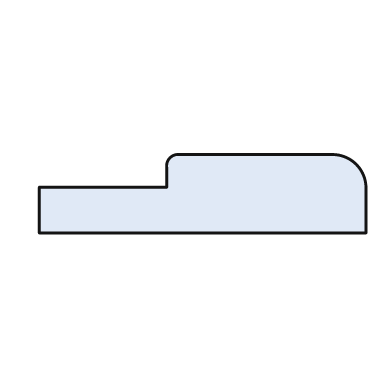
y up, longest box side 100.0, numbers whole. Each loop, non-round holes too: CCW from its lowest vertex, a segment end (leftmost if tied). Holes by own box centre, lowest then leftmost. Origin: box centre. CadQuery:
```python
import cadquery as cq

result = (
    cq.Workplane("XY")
    .moveTo(-50.0, -12.0)
    .lineTo(50.0, -12.0)
    .lineTo(50.0, 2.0)
    .threePointArc((47.0, 9.0), (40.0, 12.0))
    .lineTo(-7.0, 12.0)
    .threePointArc((-10.0, 11.0), (-11.0, 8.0))
    .lineTo(-11.0, 2.0)
    .lineTo(-50.0, 2.0)
    .close()
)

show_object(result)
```